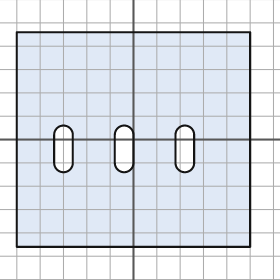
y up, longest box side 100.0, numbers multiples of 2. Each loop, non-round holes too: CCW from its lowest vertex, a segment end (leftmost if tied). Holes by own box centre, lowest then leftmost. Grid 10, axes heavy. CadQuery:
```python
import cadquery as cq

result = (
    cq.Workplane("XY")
    .moveTo(-50.0, -46.0)
    .lineTo(50.0, -46.0)
    .lineTo(50.0, 46.0)
    .lineTo(-50.0, 46.0)
    .close()
    .moveTo(-34.0, -10.0)
    .threePointArc((-30.0, -14.0), (-26.0, -10.0))
    .lineTo(-26.0, 2.0)
    .threePointArc((-30.0, 6.0), (-34.0, 2.0))
    .close()
    .moveTo(-8.0, -10.0)
    .threePointArc((-4.0, -14.0), (0.0, -10.0))
    .lineTo(0.0, 2.0)
    .threePointArc((-4.0, 6.0), (-8.0, 2.0))
    .close()
    .moveTo(18.0, -10.0)
    .threePointArc((22.0, -14.0), (26.0, -10.0))
    .lineTo(26.0, 2.0)
    .threePointArc((22.0, 6.0), (18.0, 2.0))
    .close()
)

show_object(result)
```